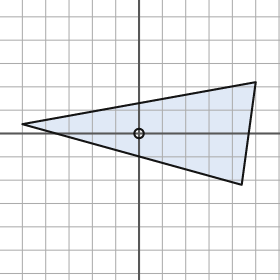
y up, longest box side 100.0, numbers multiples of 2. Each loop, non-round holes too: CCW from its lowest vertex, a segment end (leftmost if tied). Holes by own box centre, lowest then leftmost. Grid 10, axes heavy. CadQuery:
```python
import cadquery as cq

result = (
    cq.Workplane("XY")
    .moveTo(44.0, -22.0)
    .lineTo(50.0, 22.0)
    .lineTo(-50.0, 4.0)
    .close()
    .moveTo(0.0, 0.0)
    .circle(2.0)
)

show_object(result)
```